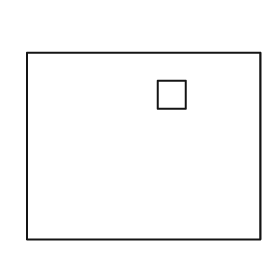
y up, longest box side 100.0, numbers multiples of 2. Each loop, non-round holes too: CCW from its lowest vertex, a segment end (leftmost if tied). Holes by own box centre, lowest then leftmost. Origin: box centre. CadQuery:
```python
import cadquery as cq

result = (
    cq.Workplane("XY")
    .moveTo(-50.0, -40.0)
    .lineTo(50.0, -40.0)
    .lineTo(50.0, 40.0)
    .lineTo(-50.0, 40.0)
    .close()
    .moveTo(6.0, 16.0)
    .lineTo(18.0, 16.0)
    .lineTo(18.0, 28.0)
    .lineTo(6.0, 28.0)
    .close()
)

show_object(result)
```